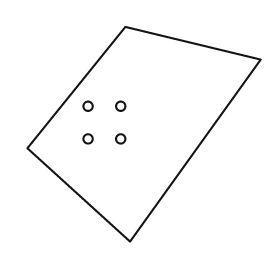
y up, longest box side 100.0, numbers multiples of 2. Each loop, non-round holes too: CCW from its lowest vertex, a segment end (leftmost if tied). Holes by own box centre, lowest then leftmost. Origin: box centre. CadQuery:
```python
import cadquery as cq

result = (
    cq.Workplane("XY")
    .moveTo(-6.0, -46.0)
    .lineTo(50.0, 32.0)
    .lineTo(-8.0, 46.0)
    .lineTo(-50.0, -6.0)
    .close()
    .moveTo(-24.0, -2.0)
    .circle(2.0)
    .moveTo(-10.0, -2.0)
    .circle(2.0)
    .moveTo(-24.0, 12.0)
    .circle(2.0)
    .moveTo(-10.0, 12.0)
    .circle(2.0)
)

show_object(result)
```